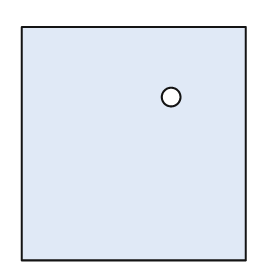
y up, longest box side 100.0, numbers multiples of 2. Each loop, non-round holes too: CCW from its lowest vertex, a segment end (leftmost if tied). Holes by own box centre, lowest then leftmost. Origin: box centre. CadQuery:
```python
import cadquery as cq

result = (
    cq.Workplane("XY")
    .moveTo(-48.0, -50.0)
    .lineTo(48.0, -50.0)
    .lineTo(48.0, 50.0)
    .lineTo(-48.0, 50.0)
    .close()
    .moveTo(16.0, 20.0)
    .circle(4.0)
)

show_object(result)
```